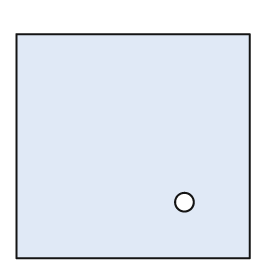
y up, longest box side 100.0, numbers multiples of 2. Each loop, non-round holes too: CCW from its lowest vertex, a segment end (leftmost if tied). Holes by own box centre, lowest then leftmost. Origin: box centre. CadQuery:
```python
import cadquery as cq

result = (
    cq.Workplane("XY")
    .moveTo(-50.0, -48.0)
    .lineTo(50.0, -48.0)
    .lineTo(50.0, 48.0)
    .lineTo(-50.0, 48.0)
    .close()
    .moveTo(22.0, -24.0)
    .circle(4.0)
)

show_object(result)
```